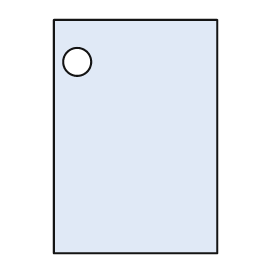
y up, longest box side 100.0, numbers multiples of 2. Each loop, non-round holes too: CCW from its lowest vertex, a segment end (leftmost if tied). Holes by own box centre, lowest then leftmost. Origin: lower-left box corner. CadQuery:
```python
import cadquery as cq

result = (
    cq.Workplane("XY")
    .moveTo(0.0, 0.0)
    .lineTo(70.0, 0.0)
    .lineTo(70.0, 100.0)
    .lineTo(0.0, 100.0)
    .close()
    .moveTo(10.0, 82.0)
    .circle(6.0)
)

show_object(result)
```